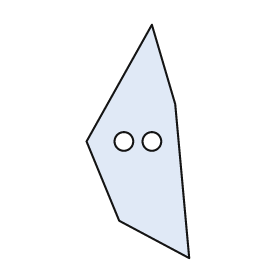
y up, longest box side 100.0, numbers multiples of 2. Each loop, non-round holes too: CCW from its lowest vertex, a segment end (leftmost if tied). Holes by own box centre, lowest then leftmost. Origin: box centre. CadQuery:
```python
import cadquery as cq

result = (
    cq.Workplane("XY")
    .moveTo(22.0, -50.0)
    .lineTo(16.0, 16.0)
    .lineTo(6.0, 50.0)
    .lineTo(-22.0, 0.0)
    .lineTo(-8.0, -34.0)
    .close()
    .moveTo(-6.0, 0.0)
    .circle(4.0)
    .moveTo(6.0, 0.0)
    .circle(4.0)
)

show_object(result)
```